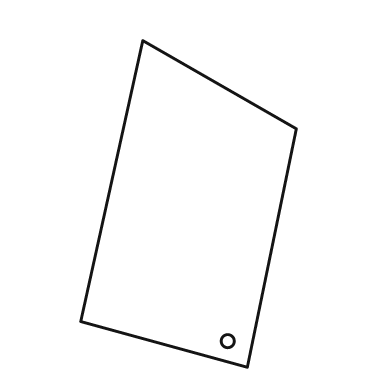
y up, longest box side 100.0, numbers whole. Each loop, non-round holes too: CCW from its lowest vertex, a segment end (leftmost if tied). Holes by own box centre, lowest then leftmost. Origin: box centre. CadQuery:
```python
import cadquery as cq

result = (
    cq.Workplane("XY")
    .moveTo(18.0, -50.0)
    .lineTo(33.0, 23.0)
    .lineTo(-14.0, 50.0)
    .lineTo(-33.0, -36.0)
    .close()
    .moveTo(12.0, -42.0)
    .circle(2.0)
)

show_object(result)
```